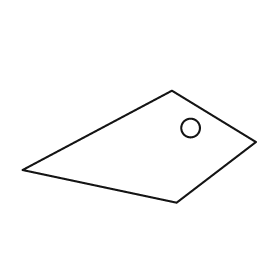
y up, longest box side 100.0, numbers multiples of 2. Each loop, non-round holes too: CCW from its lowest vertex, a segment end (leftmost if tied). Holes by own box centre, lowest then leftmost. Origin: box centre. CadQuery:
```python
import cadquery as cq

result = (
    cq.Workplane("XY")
    .moveTo(16.0, -24.0)
    .lineTo(50.0, 2.0)
    .lineTo(14.0, 24.0)
    .lineTo(-50.0, -10.0)
    .close()
    .moveTo(22.0, 8.0)
    .circle(4.0)
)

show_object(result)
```